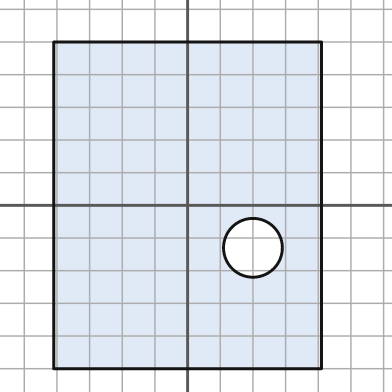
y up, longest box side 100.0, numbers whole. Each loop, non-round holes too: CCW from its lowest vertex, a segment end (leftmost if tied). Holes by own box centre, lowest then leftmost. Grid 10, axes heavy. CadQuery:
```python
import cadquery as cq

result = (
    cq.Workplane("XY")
    .moveTo(-41.0, -50.0)
    .lineTo(41.0, -50.0)
    .lineTo(41.0, 50.0)
    .lineTo(-41.0, 50.0)
    .close()
    .moveTo(20.0, -13.0)
    .circle(9.0)
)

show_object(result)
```